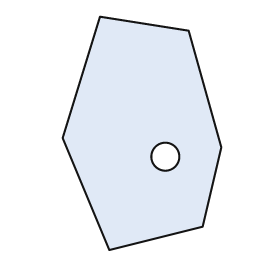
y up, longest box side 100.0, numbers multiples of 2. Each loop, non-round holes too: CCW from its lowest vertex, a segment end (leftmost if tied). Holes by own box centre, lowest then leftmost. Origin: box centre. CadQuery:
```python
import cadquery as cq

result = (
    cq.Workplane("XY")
    .moveTo(-14.0, -50.0)
    .lineTo(26.0, -40.0)
    .lineTo(34.0, -6.0)
    .lineTo(20.0, 44.0)
    .lineTo(-18.0, 50.0)
    .lineTo(-34.0, -2.0)
    .close()
    .moveTo(10.0, -10.0)
    .circle(6.0)
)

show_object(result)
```